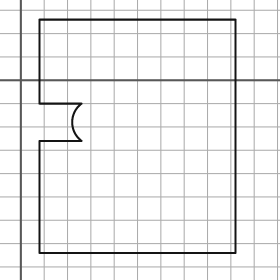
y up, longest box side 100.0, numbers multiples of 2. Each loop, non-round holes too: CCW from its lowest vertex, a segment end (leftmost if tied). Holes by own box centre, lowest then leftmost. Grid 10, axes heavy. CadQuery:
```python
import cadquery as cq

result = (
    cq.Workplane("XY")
    .moveTo(8.0, -74.0)
    .lineTo(92.0, -74.0)
    .lineTo(92.0, 26.0)
    .lineTo(8.0, 26.0)
    .lineTo(8.0, -10.0)
    .lineTo(26.0, -10.0)
    .threePointArc((22.0, -18.0), (26.0, -26.0))
    .lineTo(8.0, -26.0)
    .close()
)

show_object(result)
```